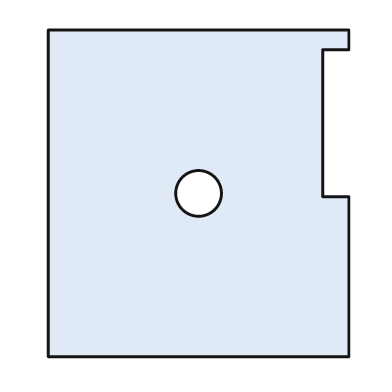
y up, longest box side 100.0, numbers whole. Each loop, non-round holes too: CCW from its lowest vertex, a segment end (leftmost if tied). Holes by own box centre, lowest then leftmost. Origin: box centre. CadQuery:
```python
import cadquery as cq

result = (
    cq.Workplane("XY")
    .moveTo(-46.0, -50.0)
    .lineTo(46.0, -50.0)
    .lineTo(46.0, -1.0)
    .lineTo(38.0, -1.0)
    .lineTo(38.0, 44.0)
    .lineTo(46.0, 44.0)
    .lineTo(46.0, 50.0)
    .lineTo(-46.0, 50.0)
    .close()
    .moveTo(0.0, 0.0)
    .circle(7.0)
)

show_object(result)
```